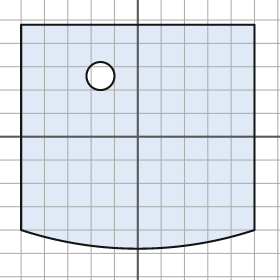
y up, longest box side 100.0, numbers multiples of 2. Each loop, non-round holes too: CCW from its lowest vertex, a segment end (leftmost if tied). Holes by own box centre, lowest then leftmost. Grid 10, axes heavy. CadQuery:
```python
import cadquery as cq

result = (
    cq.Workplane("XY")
    .moveTo(-50.0, -40.0)
    .threePointArc((0.0, -48.0), (50.0, -40.0))
    .lineTo(50.0, 48.0)
    .lineTo(-50.0, 48.0)
    .close()
    .moveTo(-16.0, 26.0)
    .circle(6.0)
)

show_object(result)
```